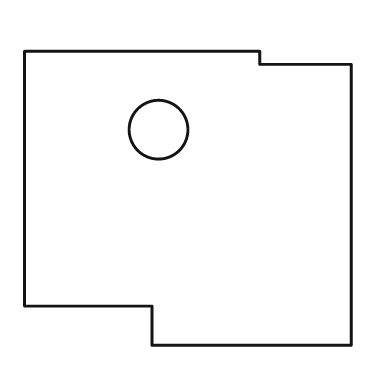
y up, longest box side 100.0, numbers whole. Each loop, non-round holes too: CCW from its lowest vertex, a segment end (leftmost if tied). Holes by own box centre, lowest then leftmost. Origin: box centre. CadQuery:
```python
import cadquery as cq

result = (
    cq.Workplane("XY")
    .moveTo(-11.0, -45.0)
    .lineTo(50.0, -45.0)
    .lineTo(50.0, 41.0)
    .lineTo(22.0, 41.0)
    .lineTo(22.0, 45.0)
    .lineTo(-50.0, 45.0)
    .lineTo(-50.0, -33.0)
    .lineTo(-11.0, -33.0)
    .close()
    .moveTo(-9.0, 21.0)
    .circle(9.0)
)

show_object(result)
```